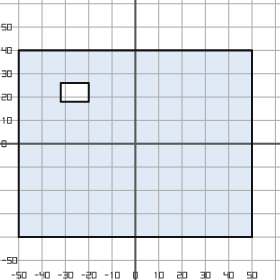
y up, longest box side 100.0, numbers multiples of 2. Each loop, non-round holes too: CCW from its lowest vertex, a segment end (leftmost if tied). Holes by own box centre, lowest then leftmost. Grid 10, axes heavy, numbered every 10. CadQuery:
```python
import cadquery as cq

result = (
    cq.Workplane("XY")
    .moveTo(-50.0, -40.0)
    .lineTo(50.0, -40.0)
    .lineTo(50.0, 40.0)
    .lineTo(-50.0, 40.0)
    .close()
    .moveTo(-32.0, 18.0)
    .lineTo(-20.0, 18.0)
    .lineTo(-20.0, 26.0)
    .lineTo(-32.0, 26.0)
    .close()
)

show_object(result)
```